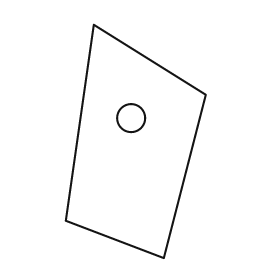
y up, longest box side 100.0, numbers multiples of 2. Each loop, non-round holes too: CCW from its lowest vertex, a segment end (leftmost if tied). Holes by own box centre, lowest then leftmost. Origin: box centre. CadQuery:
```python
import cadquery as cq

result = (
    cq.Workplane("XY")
    .moveTo(12.0, -50.0)
    .lineTo(30.0, 20.0)
    .lineTo(-18.0, 50.0)
    .lineTo(-30.0, -34.0)
    .close()
    .moveTo(-2.0, 10.0)
    .circle(6.0)
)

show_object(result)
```